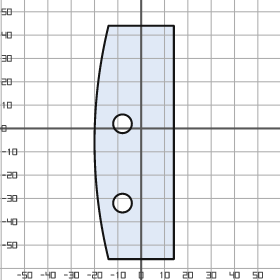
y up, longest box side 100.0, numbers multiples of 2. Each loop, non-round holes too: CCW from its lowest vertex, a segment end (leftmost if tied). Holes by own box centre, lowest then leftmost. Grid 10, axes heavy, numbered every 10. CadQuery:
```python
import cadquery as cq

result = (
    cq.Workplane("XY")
    .moveTo(-14.0, -56.0)
    .lineTo(14.0, -56.0)
    .lineTo(14.0, 44.0)
    .lineTo(-14.0, 44.0)
    .threePointArc((-20.0, -6.0), (-14.0, -56.0))
    .close()
    .moveTo(-8.0, -32.0)
    .circle(4.0)
    .moveTo(-8.0, 2.0)
    .circle(4.0)
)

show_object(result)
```